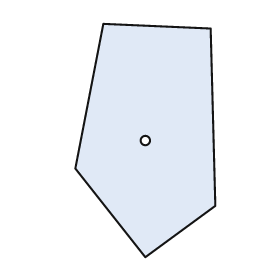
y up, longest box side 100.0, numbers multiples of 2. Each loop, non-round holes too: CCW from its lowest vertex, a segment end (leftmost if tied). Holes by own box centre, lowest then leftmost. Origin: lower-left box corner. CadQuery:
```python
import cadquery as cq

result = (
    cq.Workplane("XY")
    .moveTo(30.0, 0.0)
    .lineTo(60.0, 22.0)
    .lineTo(58.0, 98.0)
    .lineTo(12.0, 100.0)
    .lineTo(0.0, 38.0)
    .close()
    .moveTo(30.0, 50.0)
    .circle(2.0)
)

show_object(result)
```